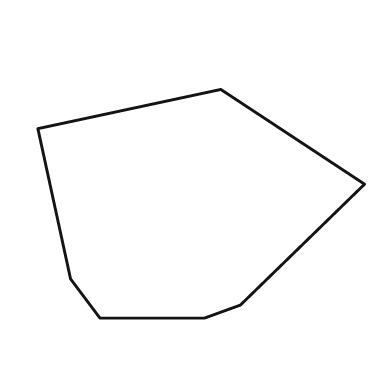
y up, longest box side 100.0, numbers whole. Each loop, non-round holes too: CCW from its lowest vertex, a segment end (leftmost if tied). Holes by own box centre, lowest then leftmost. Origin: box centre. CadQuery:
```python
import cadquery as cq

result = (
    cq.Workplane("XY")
    .moveTo(-31.0, -35.0)
    .lineTo(1.0, -35.0)
    .lineTo(12.0, -31.0)
    .lineTo(50.0, 6.0)
    .lineTo(6.0, 35.0)
    .lineTo(-50.0, 23.0)
    .lineTo(-40.0, -23.0)
    .close()
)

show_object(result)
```